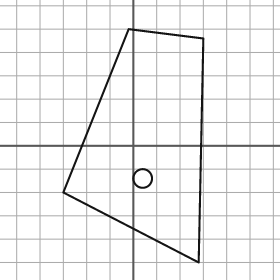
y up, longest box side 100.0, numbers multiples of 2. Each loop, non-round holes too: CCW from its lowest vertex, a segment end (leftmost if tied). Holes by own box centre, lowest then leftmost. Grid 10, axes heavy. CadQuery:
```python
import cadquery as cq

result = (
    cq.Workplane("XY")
    .moveTo(28.0, -50.0)
    .lineTo(30.0, 46.0)
    .lineTo(-2.0, 50.0)
    .lineTo(-30.0, -20.0)
    .close()
    .moveTo(4.0, -14.0)
    .circle(4.0)
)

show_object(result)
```